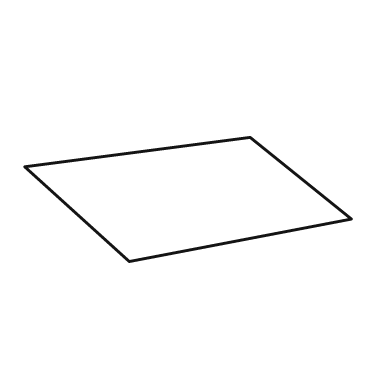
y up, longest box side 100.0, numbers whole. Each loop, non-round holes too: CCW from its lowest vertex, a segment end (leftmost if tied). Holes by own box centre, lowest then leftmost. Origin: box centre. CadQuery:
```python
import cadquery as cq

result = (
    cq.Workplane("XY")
    .moveTo(-18.0, -19.0)
    .lineTo(50.0, -6.0)
    .lineTo(19.0, 19.0)
    .lineTo(-50.0, 10.0)
    .close()
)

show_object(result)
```